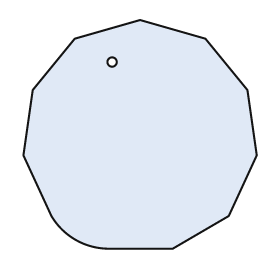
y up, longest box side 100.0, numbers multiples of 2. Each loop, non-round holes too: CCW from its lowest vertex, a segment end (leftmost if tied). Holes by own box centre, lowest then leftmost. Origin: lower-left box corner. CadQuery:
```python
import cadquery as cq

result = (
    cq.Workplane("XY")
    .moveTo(36.0, 0.0)
    .lineTo(64.0, 0.0)
    .lineTo(88.0, 14.0)
    .lineTo(100.0, 40.0)
    .lineTo(96.0, 68.0)
    .lineTo(78.0, 90.0)
    .lineTo(50.0, 98.0)
    .lineTo(22.0, 90.0)
    .lineTo(4.0, 68.0)
    .lineTo(0.0, 40.0)
    .lineTo(12.0, 14.0)
    .threePointArc((22.0, 4.0), (36.0, 0.0))
    .close()
    .moveTo(38.0, 80.0)
    .circle(2.0)
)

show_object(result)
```